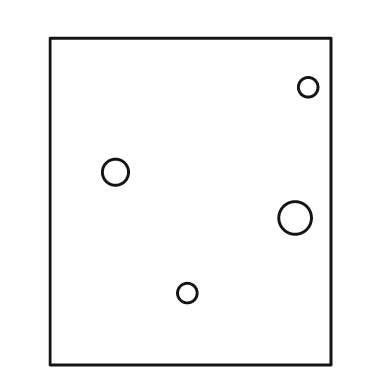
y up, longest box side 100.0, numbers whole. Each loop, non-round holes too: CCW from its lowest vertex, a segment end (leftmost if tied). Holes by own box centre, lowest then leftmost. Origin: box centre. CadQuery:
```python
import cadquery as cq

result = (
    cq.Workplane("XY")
    .moveTo(-43.0, -50.0)
    .lineTo(43.0, -50.0)
    .lineTo(43.0, 50.0)
    .lineTo(-43.0, 50.0)
    .close()
    .moveTo(-1.0, -28.0)
    .circle(3.0)
    .moveTo(32.0, -5.0)
    .circle(5.0)
    .moveTo(-23.0, 9.0)
    .circle(4.0)
    .moveTo(36.0, 35.0)
    .circle(3.0)
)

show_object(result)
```